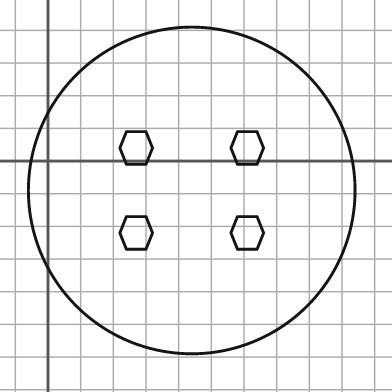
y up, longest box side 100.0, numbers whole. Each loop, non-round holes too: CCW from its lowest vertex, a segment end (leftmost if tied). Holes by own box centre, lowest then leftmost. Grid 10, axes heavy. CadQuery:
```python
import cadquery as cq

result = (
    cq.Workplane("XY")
    .moveTo(44.0, -9.0)
    .circle(50.0)
    .moveTo(24.0, -27.0)
    .lineTo(30.0, -27.0)
    .lineTo(32.0, -22.0)
    .lineTo(30.0, -17.0)
    .lineTo(24.0, -17.0)
    .lineTo(22.0, -22.0)
    .close()
    .moveTo(58.0, -27.0)
    .lineTo(64.0, -27.0)
    .lineTo(66.0, -22.0)
    .lineTo(64.0, -17.0)
    .lineTo(58.0, -17.0)
    .lineTo(56.0, -22.0)
    .close()
    .moveTo(24.0, -1.0)
    .lineTo(30.0, -1.0)
    .lineTo(32.0, 4.0)
    .lineTo(30.0, 9.0)
    .lineTo(24.0, 9.0)
    .lineTo(22.0, 4.0)
    .close()
    .moveTo(58.0, -1.0)
    .lineTo(64.0, -1.0)
    .lineTo(66.0, 4.0)
    .lineTo(64.0, 9.0)
    .lineTo(58.0, 9.0)
    .lineTo(56.0, 4.0)
    .close()
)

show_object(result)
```